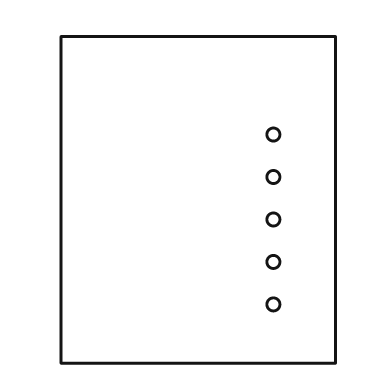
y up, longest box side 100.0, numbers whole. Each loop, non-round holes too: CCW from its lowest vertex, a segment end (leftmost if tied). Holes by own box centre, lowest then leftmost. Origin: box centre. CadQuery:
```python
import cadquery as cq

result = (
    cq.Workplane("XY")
    .moveTo(-42.0, -50.0)
    .lineTo(42.0, -50.0)
    .lineTo(42.0, 50.0)
    .lineTo(-42.0, 50.0)
    .close()
    .moveTo(23.0, -32.0)
    .circle(2.0)
    .moveTo(23.0, -19.0)
    .circle(2.0)
    .moveTo(23.0, -6.0)
    .circle(2.0)
    .moveTo(23.0, 7.0)
    .circle(2.0)
    .moveTo(23.0, 20.0)
    .circle(2.0)
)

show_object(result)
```